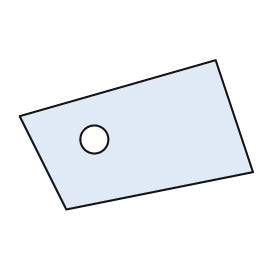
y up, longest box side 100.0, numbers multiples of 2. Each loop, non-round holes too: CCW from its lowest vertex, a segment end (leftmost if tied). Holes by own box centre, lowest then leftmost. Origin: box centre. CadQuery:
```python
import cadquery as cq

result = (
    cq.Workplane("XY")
    .moveTo(-30.0, -32.0)
    .lineTo(50.0, -16.0)
    .lineTo(34.0, 32.0)
    .lineTo(-50.0, 8.0)
    .close()
    .moveTo(-18.0, -2.0)
    .circle(6.0)
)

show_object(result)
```